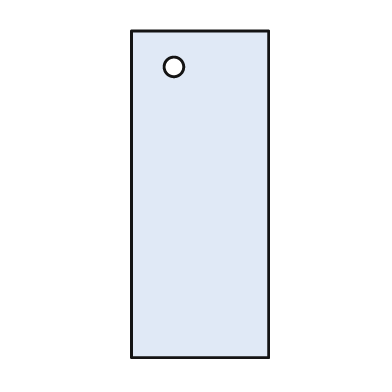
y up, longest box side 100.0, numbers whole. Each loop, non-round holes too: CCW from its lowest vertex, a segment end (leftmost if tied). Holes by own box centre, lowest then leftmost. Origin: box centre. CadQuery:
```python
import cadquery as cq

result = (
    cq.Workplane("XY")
    .moveTo(-21.0, -50.0)
    .lineTo(21.0, -50.0)
    .lineTo(21.0, 50.0)
    .lineTo(-21.0, 50.0)
    .close()
    .moveTo(-8.0, 39.0)
    .circle(3.0)
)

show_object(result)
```